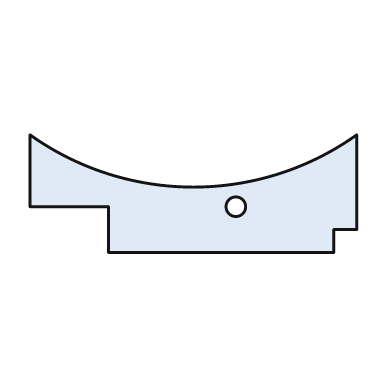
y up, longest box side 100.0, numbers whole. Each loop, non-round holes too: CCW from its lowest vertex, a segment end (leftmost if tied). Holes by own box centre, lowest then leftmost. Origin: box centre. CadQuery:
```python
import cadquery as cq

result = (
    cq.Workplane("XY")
    .moveTo(-26.0, -18.0)
    .lineTo(43.0, -18.0)
    .lineTo(43.0, -11.0)
    .lineTo(50.0, -11.0)
    .lineTo(50.0, 18.0)
    .threePointArc((0.0, 2.0), (-50.0, 18.0))
    .lineTo(-50.0, -4.0)
    .lineTo(-26.0, -4.0)
    .close()
    .moveTo(13.0, -4.0)
    .circle(3.0)
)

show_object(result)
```